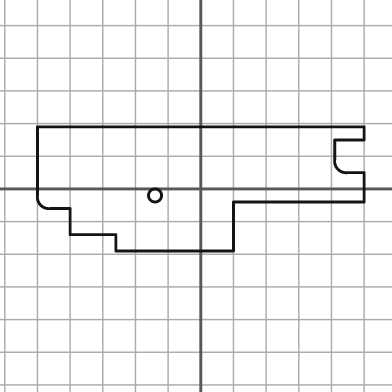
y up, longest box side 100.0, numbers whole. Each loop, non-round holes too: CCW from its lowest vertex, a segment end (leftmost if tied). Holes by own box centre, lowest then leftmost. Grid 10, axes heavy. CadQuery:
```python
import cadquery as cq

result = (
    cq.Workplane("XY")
    .moveTo(-26.0, -19.0)
    .lineTo(10.0, -19.0)
    .lineTo(10.0, -4.0)
    .lineTo(50.0, -4.0)
    .lineTo(50.0, 5.0)
    .lineTo(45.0, 5.0)
    .threePointArc((42.0, 6.0), (41.0, 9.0))
    .lineTo(41.0, 15.0)
    .lineTo(50.0, 15.0)
    .lineTo(50.0, 19.0)
    .lineTo(-50.0, 19.0)
    .lineTo(-50.0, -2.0)
    .threePointArc((-49.0, -5.0), (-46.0, -6.0))
    .lineTo(-40.0, -6.0)
    .lineTo(-40.0, -14.0)
    .lineTo(-26.0, -14.0)
    .close()
    .moveTo(-14.0, -2.0)
    .circle(2.0)
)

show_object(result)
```